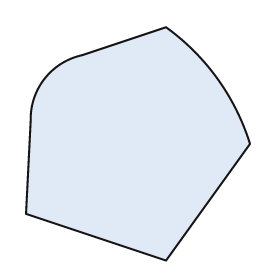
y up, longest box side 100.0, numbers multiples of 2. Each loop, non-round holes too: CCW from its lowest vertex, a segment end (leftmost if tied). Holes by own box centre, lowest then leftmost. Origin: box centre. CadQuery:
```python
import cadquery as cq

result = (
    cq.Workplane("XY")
    .moveTo(12.0, -50.0)
    .lineTo(48.0, 0.0)
    .threePointArc((34.0, 28.0), (12.0, 50.0))
    .lineTo(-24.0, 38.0)
    .threePointArc((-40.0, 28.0), (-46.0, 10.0))
    .lineTo(-48.0, -30.0)
    .close()
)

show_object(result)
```